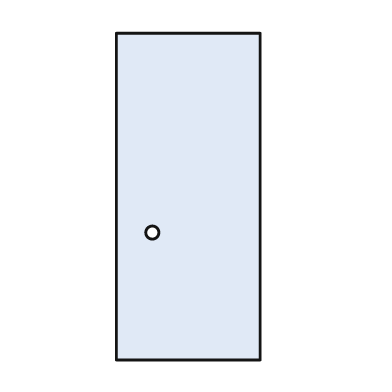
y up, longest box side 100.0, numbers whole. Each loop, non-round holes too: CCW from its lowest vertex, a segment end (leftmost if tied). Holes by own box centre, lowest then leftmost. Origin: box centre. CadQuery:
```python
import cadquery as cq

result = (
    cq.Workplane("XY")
    .moveTo(-22.0, -50.0)
    .lineTo(22.0, -50.0)
    .lineTo(22.0, 50.0)
    .lineTo(-22.0, 50.0)
    .close()
    .moveTo(-11.0, -11.0)
    .circle(2.0)
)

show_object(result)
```